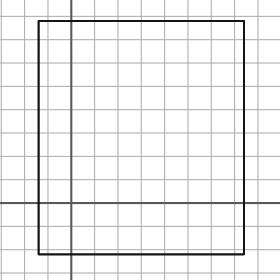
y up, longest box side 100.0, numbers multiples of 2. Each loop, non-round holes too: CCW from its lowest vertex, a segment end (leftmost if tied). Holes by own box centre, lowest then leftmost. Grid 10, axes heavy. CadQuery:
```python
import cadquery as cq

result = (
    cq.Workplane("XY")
    .moveTo(-14.0, -22.0)
    .lineTo(74.0, -22.0)
    .lineTo(74.0, 78.0)
    .lineTo(-14.0, 78.0)
    .close()
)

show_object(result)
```